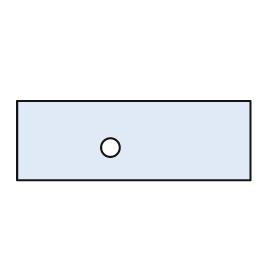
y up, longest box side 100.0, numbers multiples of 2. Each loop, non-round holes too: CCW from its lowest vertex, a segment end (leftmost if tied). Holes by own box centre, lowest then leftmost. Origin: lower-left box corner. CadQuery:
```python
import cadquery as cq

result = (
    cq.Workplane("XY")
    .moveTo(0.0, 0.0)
    .lineTo(100.0, 0.0)
    .lineTo(100.0, 34.0)
    .lineTo(0.0, 34.0)
    .close()
    .moveTo(40.0, 14.0)
    .circle(4.0)
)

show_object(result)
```